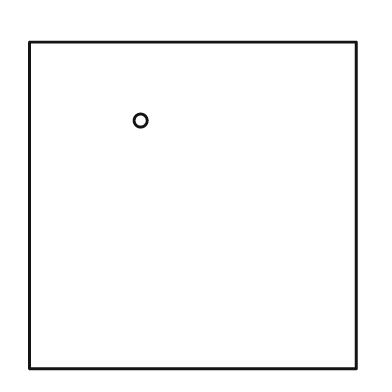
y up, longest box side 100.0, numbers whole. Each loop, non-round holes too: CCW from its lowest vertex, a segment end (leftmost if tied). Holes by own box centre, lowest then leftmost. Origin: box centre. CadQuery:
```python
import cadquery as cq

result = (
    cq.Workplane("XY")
    .moveTo(-50.0, -50.0)
    .lineTo(50.0, -50.0)
    .lineTo(50.0, 50.0)
    .lineTo(-50.0, 50.0)
    .close()
    .moveTo(-16.0, 26.0)
    .circle(2.0)
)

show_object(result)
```